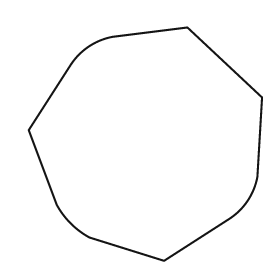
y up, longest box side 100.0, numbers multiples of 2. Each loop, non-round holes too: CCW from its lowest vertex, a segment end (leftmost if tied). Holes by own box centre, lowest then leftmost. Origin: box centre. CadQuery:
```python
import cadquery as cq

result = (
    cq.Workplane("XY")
    .moveTo(8.0, -50.0)
    .lineTo(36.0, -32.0)
    .threePointArc((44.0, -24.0), (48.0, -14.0))
    .lineTo(50.0, 20.0)
    .lineTo(18.0, 50.0)
    .lineTo(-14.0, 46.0)
    .threePointArc((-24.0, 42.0), (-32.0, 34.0))
    .lineTo(-50.0, 6.0)
    .lineTo(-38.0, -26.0)
    .threePointArc((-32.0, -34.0), (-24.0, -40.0))
    .close()
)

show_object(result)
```